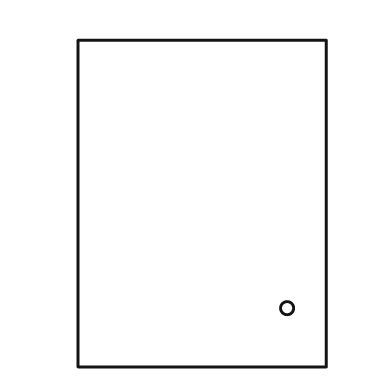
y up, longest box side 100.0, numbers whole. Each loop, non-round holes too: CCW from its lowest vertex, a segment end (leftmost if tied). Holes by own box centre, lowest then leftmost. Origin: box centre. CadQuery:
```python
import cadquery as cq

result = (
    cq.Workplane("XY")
    .moveTo(-38.0, -50.0)
    .lineTo(38.0, -50.0)
    .lineTo(38.0, 50.0)
    .lineTo(-38.0, 50.0)
    .close()
    .moveTo(26.0, -32.0)
    .circle(2.0)
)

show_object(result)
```